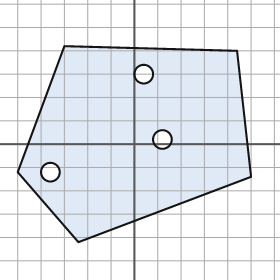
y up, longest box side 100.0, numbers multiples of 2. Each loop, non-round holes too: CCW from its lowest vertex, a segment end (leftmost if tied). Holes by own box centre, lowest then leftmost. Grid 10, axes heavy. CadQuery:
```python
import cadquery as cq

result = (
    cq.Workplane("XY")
    .moveTo(-24.0, -42.0)
    .lineTo(50.0, -14.0)
    .lineTo(44.0, 40.0)
    .lineTo(-30.0, 42.0)
    .lineTo(-50.0, -12.0)
    .close()
    .moveTo(-36.0, -12.0)
    .circle(4.0)
    .moveTo(12.0, 2.0)
    .circle(4.0)
    .moveTo(4.0, 30.0)
    .circle(4.0)
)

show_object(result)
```